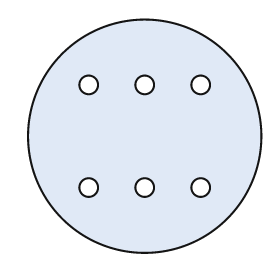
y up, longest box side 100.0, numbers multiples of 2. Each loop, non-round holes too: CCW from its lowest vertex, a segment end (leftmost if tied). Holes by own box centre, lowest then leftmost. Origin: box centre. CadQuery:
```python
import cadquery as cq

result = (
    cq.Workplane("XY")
    .moveTo(0.0, 0.0)
    .circle(50.0)
    .moveTo(-24.0, -22.0)
    .circle(4.0)
    .moveTo(0.0, -22.0)
    .circle(4.0)
    .moveTo(24.0, -22.0)
    .circle(4.0)
    .moveTo(-24.0, 22.0)
    .circle(4.0)
    .moveTo(0.0, 22.0)
    .circle(4.0)
    .moveTo(24.0, 22.0)
    .circle(4.0)
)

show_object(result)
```